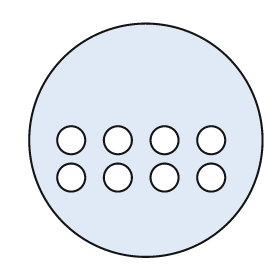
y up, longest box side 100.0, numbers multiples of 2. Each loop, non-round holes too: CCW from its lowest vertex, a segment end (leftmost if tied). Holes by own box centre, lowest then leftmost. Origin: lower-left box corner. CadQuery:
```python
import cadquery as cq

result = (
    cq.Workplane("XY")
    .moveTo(50.0, 50.0)
    .circle(50.0)
    .moveTo(18.0, 34.0)
    .circle(6.0)
    .moveTo(38.0, 34.0)
    .circle(6.0)
    .moveTo(58.0, 34.0)
    .circle(6.0)
    .moveTo(78.0, 34.0)
    .circle(6.0)
    .moveTo(18.0, 50.0)
    .circle(6.0)
    .moveTo(38.0, 50.0)
    .circle(6.0)
    .moveTo(58.0, 50.0)
    .circle(6.0)
    .moveTo(78.0, 50.0)
    .circle(6.0)
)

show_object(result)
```